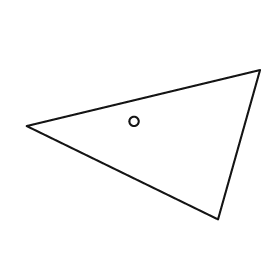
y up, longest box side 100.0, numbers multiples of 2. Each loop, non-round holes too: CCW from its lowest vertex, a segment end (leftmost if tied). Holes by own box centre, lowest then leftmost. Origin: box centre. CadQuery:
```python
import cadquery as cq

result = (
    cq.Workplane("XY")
    .moveTo(32.0, -32.0)
    .lineTo(50.0, 32.0)
    .lineTo(-50.0, 8.0)
    .close()
    .moveTo(-4.0, 10.0)
    .circle(2.0)
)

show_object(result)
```